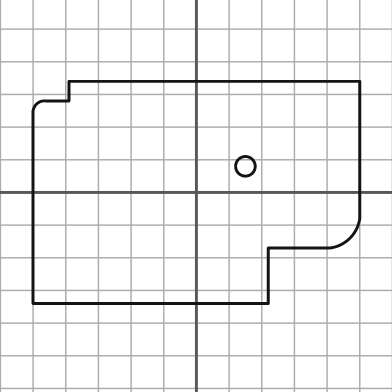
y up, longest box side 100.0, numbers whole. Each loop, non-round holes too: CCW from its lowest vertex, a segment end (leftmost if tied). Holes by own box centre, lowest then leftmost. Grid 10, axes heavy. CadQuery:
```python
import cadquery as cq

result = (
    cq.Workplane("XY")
    .moveTo(-50.0, -34.0)
    .lineTo(22.0, -34.0)
    .lineTo(22.0, -17.0)
    .lineTo(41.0, -17.0)
    .threePointArc((47.0, -14.0), (50.0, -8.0))
    .lineTo(50.0, 34.0)
    .lineTo(-39.0, 34.0)
    .lineTo(-39.0, 28.0)
    .lineTo(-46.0, 28.0)
    .threePointArc((-49.0, 27.0), (-50.0, 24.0))
    .close()
    .moveTo(15.0, 8.0)
    .circle(3.0)
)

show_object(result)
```